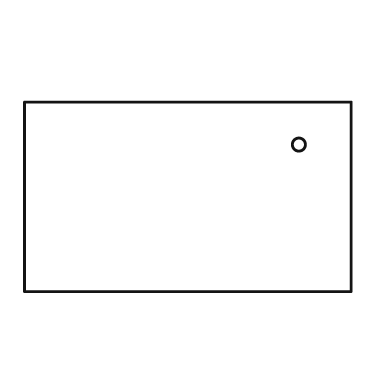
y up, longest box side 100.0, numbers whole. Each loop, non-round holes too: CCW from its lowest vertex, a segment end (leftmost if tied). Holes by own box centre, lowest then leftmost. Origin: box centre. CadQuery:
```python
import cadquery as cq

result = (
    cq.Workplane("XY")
    .moveTo(-50.0, -29.0)
    .lineTo(50.0, -29.0)
    .lineTo(50.0, 29.0)
    .lineTo(-50.0, 29.0)
    .close()
    .moveTo(34.0, 16.0)
    .circle(2.0)
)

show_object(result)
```